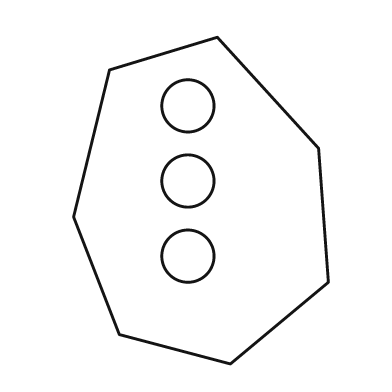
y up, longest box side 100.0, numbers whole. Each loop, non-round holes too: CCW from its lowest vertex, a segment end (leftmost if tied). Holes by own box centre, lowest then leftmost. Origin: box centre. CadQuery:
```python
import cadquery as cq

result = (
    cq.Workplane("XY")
    .moveTo(9.0, -50.0)
    .lineTo(39.0, -25.0)
    .lineTo(36.0, 16.0)
    .lineTo(5.0, 50.0)
    .lineTo(-28.0, 40.0)
    .lineTo(-39.0, -5.0)
    .lineTo(-25.0, -41.0)
    .close()
    .moveTo(-4.0, -17.0)
    .circle(8.0)
    .moveTo(-4.0, 6.0)
    .circle(8.0)
    .moveTo(-4.0, 29.0)
    .circle(8.0)
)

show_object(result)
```